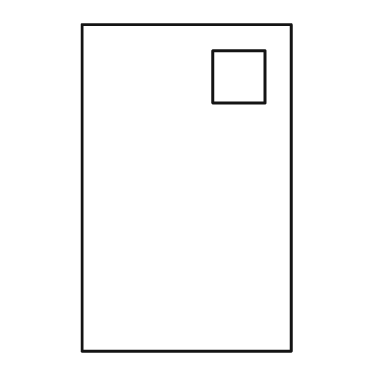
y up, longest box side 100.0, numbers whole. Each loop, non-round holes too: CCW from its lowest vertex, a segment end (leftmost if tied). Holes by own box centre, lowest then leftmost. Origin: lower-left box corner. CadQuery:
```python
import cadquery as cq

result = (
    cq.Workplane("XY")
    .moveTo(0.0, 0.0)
    .lineTo(64.0, 0.0)
    .lineTo(64.0, 100.0)
    .lineTo(0.0, 100.0)
    .close()
    .moveTo(40.0, 76.0)
    .lineTo(56.0, 76.0)
    .lineTo(56.0, 92.0)
    .lineTo(40.0, 92.0)
    .close()
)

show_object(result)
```